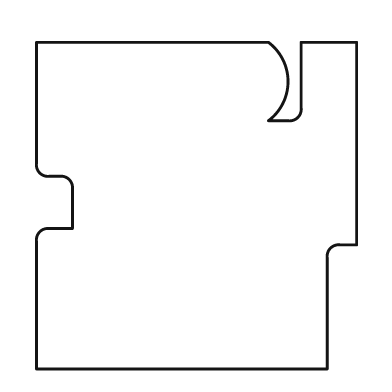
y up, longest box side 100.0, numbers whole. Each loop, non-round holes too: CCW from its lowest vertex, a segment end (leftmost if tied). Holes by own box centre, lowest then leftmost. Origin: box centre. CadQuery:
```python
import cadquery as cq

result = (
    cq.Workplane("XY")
    .moveTo(-49.0, -50.0)
    .lineTo(40.0, -50.0)
    .lineTo(40.0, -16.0)
    .threePointArc((41.0, -13.0), (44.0, -12.0))
    .lineTo(49.0, -12.0)
    .lineTo(49.0, 50.0)
    .lineTo(32.0, 50.0)
    .lineTo(32.0, 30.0)
    .threePointArc((31.0, 27.0), (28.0, 26.0))
    .lineTo(22.0, 26.0)
    .threePointArc((28.0, 38.0), (22.0, 50.0))
    .lineTo(-49.0, 50.0)
    .lineTo(-49.0, 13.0)
    .threePointArc((-48.0, 10.0), (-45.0, 9.0))
    .lineTo(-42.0, 9.0)
    .threePointArc((-39.0, 8.0), (-38.0, 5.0))
    .lineTo(-38.0, -7.0)
    .lineTo(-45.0, -7.0)
    .threePointArc((-48.0, -8.0), (-49.0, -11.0))
    .close()
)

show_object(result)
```